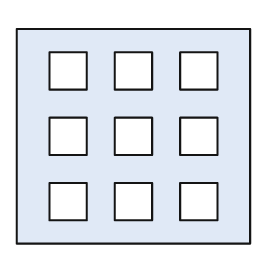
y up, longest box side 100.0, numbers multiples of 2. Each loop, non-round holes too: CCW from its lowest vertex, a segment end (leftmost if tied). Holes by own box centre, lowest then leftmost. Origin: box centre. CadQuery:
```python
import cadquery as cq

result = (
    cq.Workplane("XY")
    .moveTo(-50.0, -46.0)
    .lineTo(50.0, -46.0)
    .lineTo(50.0, 46.0)
    .lineTo(-50.0, 46.0)
    .close()
    .moveTo(-36.0, -36.0)
    .lineTo(-20.0, -36.0)
    .lineTo(-20.0, -20.0)
    .lineTo(-36.0, -20.0)
    .close()
    .moveTo(-8.0, -36.0)
    .lineTo(8.0, -36.0)
    .lineTo(8.0, -20.0)
    .lineTo(-8.0, -20.0)
    .close()
    .moveTo(20.0, -36.0)
    .lineTo(36.0, -36.0)
    .lineTo(36.0, -20.0)
    .lineTo(20.0, -20.0)
    .close()
    .moveTo(-36.0, -8.0)
    .lineTo(-20.0, -8.0)
    .lineTo(-20.0, 8.0)
    .lineTo(-36.0, 8.0)
    .close()
    .moveTo(-8.0, -8.0)
    .lineTo(8.0, -8.0)
    .lineTo(8.0, 8.0)
    .lineTo(-8.0, 8.0)
    .close()
    .moveTo(20.0, -8.0)
    .lineTo(36.0, -8.0)
    .lineTo(36.0, 8.0)
    .lineTo(20.0, 8.0)
    .close()
    .moveTo(-36.0, 20.0)
    .lineTo(-20.0, 20.0)
    .lineTo(-20.0, 36.0)
    .lineTo(-36.0, 36.0)
    .close()
    .moveTo(-8.0, 20.0)
    .lineTo(8.0, 20.0)
    .lineTo(8.0, 36.0)
    .lineTo(-8.0, 36.0)
    .close()
    .moveTo(20.0, 20.0)
    .lineTo(36.0, 20.0)
    .lineTo(36.0, 36.0)
    .lineTo(20.0, 36.0)
    .close()
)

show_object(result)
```